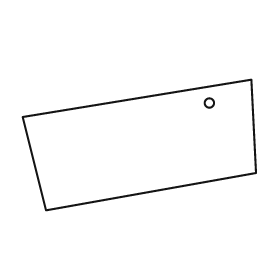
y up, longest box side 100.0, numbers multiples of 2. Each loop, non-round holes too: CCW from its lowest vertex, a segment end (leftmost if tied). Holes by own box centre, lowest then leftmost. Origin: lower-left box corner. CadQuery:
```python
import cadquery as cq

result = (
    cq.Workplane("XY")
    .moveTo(10.0, 0.0)
    .lineTo(100.0, 16.0)
    .lineTo(98.0, 56.0)
    .lineTo(0.0, 40.0)
    .close()
    .moveTo(80.0, 46.0)
    .circle(2.0)
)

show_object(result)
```